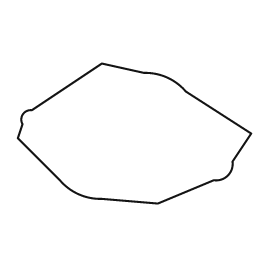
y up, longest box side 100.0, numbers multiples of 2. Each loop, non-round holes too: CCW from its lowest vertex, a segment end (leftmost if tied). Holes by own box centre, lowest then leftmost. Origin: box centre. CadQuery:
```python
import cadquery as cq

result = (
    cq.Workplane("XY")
    .moveTo(10.0, -30.0)
    .lineTo(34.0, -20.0)
    .threePointArc((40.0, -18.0), (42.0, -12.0))
    .lineTo(50.0, 0.0)
    .lineTo(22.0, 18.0)
    .threePointArc((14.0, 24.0), (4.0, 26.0))
    .lineTo(-14.0, 30.0)
    .lineTo(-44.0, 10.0)
    .threePointArc((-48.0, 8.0), (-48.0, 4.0))
    .lineTo(-50.0, -2.0)
    .lineTo(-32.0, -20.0)
    .threePointArc((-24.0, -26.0), (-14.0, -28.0))
    .close()
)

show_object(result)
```